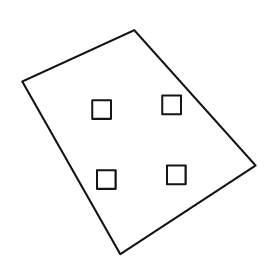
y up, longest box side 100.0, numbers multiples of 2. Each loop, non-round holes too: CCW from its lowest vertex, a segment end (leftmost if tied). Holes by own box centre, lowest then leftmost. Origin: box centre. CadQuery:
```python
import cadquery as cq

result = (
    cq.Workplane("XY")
    .moveTo(-8.0, -48.0)
    .lineTo(50.0, -10.0)
    .lineTo(-2.0, 48.0)
    .lineTo(-50.0, 26.0)
    .close()
    .moveTo(-18.0, -20.0)
    .lineTo(-10.0, -20.0)
    .lineTo(-10.0, -12.0)
    .lineTo(-18.0, -12.0)
    .close()
    .moveTo(12.0, -18.0)
    .lineTo(20.0, -18.0)
    .lineTo(20.0, -10.0)
    .lineTo(12.0, -10.0)
    .close()
    .moveTo(-20.0, 10.0)
    .lineTo(-12.0, 10.0)
    .lineTo(-12.0, 18.0)
    .lineTo(-20.0, 18.0)
    .close()
    .moveTo(10.0, 12.0)
    .lineTo(18.0, 12.0)
    .lineTo(18.0, 20.0)
    .lineTo(10.0, 20.0)
    .close()
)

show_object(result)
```